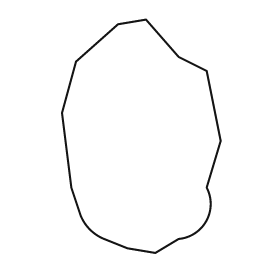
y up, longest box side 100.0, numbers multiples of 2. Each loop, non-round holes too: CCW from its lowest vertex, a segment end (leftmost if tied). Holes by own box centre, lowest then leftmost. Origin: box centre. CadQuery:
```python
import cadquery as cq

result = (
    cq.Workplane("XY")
    .moveTo(6.0, -50.0)
    .lineTo(16.0, -44.0)
    .threePointArc((28.0, -36.0), (28.0, -22.0))
    .lineTo(34.0, -2.0)
    .lineTo(28.0, 28.0)
    .lineTo(16.0, 34.0)
    .lineTo(2.0, 50.0)
    .lineTo(-10.0, 48.0)
    .lineTo(-28.0, 32.0)
    .lineTo(-34.0, 10.0)
    .lineTo(-30.0, -22.0)
    .lineTo(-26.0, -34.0)
    .threePointArc((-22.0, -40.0), (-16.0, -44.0))
    .lineTo(-6.0, -48.0)
    .close()
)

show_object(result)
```